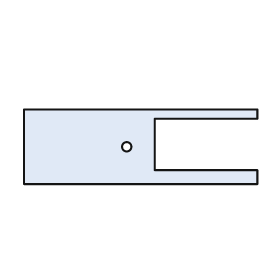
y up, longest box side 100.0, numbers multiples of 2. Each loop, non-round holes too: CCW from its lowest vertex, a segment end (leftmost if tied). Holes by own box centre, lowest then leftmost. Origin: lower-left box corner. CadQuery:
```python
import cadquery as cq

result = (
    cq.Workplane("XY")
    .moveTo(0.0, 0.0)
    .lineTo(100.0, 0.0)
    .lineTo(100.0, 6.0)
    .lineTo(56.0, 6.0)
    .lineTo(56.0, 28.0)
    .lineTo(100.0, 28.0)
    .lineTo(100.0, 32.0)
    .lineTo(0.0, 32.0)
    .close()
    .moveTo(44.0, 16.0)
    .circle(2.0)
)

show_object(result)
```